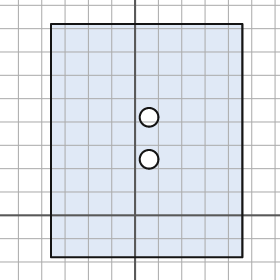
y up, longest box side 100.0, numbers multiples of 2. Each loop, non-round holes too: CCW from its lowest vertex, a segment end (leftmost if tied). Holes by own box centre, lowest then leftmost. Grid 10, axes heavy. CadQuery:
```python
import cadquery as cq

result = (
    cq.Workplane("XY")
    .moveTo(-36.0, -18.0)
    .lineTo(46.0, -18.0)
    .lineTo(46.0, 82.0)
    .lineTo(-36.0, 82.0)
    .close()
    .moveTo(6.0, 24.0)
    .circle(4.0)
    .moveTo(6.0, 42.0)
    .circle(4.0)
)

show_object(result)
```